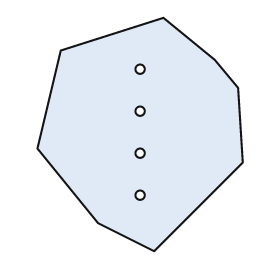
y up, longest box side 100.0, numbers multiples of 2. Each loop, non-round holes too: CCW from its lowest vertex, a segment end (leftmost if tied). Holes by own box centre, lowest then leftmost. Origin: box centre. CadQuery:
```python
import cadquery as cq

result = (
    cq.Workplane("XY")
    .moveTo(6.0, -50.0)
    .lineTo(44.0, -12.0)
    .lineTo(42.0, 20.0)
    .lineTo(32.0, 32.0)
    .lineTo(10.0, 50.0)
    .lineTo(-34.0, 36.0)
    .lineTo(-44.0, -6.0)
    .lineTo(-18.0, -38.0)
    .close()
    .moveTo(0.0, -26.0)
    .circle(2.0)
    .moveTo(0.0, -8.0)
    .circle(2.0)
    .moveTo(0.0, 10.0)
    .circle(2.0)
    .moveTo(0.0, 28.0)
    .circle(2.0)
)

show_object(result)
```